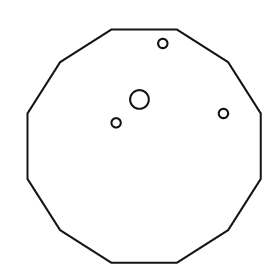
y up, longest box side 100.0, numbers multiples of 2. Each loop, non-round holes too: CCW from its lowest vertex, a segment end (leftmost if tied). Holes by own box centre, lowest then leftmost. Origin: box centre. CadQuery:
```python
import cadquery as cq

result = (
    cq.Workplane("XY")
    .moveTo(-14.0, -50.0)
    .lineTo(14.0, -50.0)
    .lineTo(36.0, -36.0)
    .lineTo(50.0, -14.0)
    .lineTo(50.0, 14.0)
    .lineTo(36.0, 36.0)
    .lineTo(14.0, 50.0)
    .lineTo(-14.0, 50.0)
    .lineTo(-36.0, 36.0)
    .lineTo(-50.0, 14.0)
    .lineTo(-50.0, -14.0)
    .lineTo(-36.0, -36.0)
    .close()
    .moveTo(-12.0, 10.0)
    .circle(2.0)
    .moveTo(34.0, 14.0)
    .circle(2.0)
    .moveTo(-2.0, 20.0)
    .circle(4.0)
    .moveTo(8.0, 44.0)
    .circle(2.0)
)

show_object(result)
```